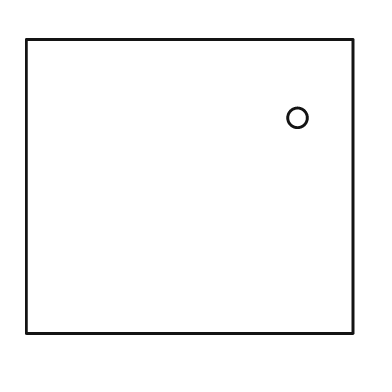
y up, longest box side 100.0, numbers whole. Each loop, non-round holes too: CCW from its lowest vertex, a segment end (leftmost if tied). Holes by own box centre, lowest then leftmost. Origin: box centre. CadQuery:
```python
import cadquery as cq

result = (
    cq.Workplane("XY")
    .moveTo(-50.0, -45.0)
    .lineTo(50.0, -45.0)
    .lineTo(50.0, 45.0)
    .lineTo(-50.0, 45.0)
    .close()
    .moveTo(33.0, 21.0)
    .circle(3.0)
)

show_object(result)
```